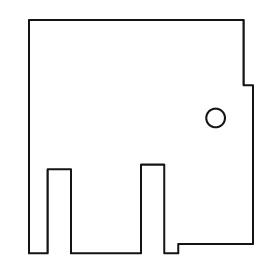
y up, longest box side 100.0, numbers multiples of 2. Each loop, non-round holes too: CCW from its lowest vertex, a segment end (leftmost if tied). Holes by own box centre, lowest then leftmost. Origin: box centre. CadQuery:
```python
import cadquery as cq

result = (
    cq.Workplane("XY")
    .moveTo(-48.0, -50.0)
    .lineTo(-40.0, -50.0)
    .lineTo(-40.0, -14.0)
    .lineTo(-30.0, -14.0)
    .lineTo(-30.0, -50.0)
    .lineTo(0.0, -50.0)
    .lineTo(0.0, -12.0)
    .lineTo(10.0, -12.0)
    .lineTo(10.0, -50.0)
    .lineTo(16.0, -50.0)
    .lineTo(16.0, -46.0)
    .lineTo(48.0, -46.0)
    .lineTo(48.0, 22.0)
    .lineTo(44.0, 22.0)
    .lineTo(44.0, 50.0)
    .lineTo(-48.0, 50.0)
    .close()
    .moveTo(32.0, 8.0)
    .circle(4.0)
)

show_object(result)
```